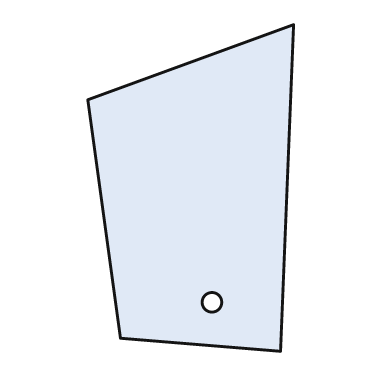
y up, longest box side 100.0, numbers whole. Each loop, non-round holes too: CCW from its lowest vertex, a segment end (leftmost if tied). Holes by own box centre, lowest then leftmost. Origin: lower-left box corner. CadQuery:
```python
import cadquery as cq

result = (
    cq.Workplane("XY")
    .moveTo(59.0, 0.0)
    .lineTo(63.0, 100.0)
    .lineTo(0.0, 77.0)
    .lineTo(10.0, 4.0)
    .close()
    .moveTo(38.0, 15.0)
    .circle(3.0)
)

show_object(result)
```